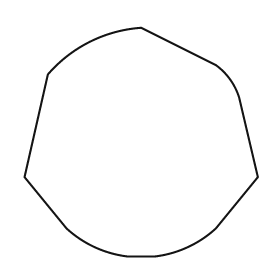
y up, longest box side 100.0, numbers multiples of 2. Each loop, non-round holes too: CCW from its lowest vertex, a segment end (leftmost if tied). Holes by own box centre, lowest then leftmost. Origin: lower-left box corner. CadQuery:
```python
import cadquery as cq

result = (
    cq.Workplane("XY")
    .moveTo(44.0, 0.0)
    .lineTo(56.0, 0.0)
    .threePointArc((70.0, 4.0), (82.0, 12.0))
    .lineTo(100.0, 34.0)
    .lineTo(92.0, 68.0)
    .threePointArc((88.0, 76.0), (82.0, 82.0))
    .lineTo(50.0, 98.0)
    .threePointArc((28.0, 92.0), (10.0, 78.0))
    .lineTo(0.0, 34.0)
    .lineTo(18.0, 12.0)
    .threePointArc((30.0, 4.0), (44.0, 0.0))
    .close()
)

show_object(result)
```